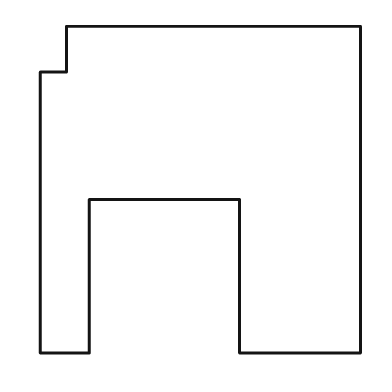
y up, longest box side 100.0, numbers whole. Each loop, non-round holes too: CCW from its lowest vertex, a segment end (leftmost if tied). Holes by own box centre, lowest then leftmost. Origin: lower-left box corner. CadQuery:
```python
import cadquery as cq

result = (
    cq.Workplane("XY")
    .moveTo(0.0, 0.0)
    .lineTo(15.0, 0.0)
    .lineTo(15.0, 47.0)
    .lineTo(61.0, 47.0)
    .lineTo(61.0, 0.0)
    .lineTo(98.0, 0.0)
    .lineTo(98.0, 100.0)
    .lineTo(8.0, 100.0)
    .lineTo(8.0, 86.0)
    .lineTo(0.0, 86.0)
    .close()
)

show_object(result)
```